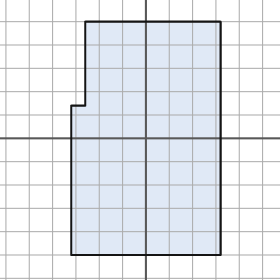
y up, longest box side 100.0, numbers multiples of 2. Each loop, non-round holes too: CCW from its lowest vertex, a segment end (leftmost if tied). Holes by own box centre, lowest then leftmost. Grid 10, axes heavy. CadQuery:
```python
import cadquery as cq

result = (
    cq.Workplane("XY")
    .moveTo(-32.0, -50.0)
    .lineTo(32.0, -50.0)
    .lineTo(32.0, 50.0)
    .lineTo(-26.0, 50.0)
    .lineTo(-26.0, 14.0)
    .lineTo(-32.0, 14.0)
    .close()
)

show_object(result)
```